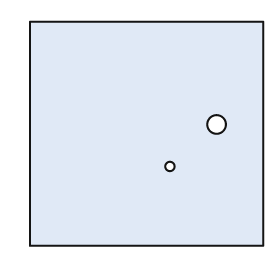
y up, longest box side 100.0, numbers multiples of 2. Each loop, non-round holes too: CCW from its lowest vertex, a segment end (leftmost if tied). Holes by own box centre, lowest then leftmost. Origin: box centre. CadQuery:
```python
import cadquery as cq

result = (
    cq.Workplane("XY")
    .moveTo(-50.0, -48.0)
    .lineTo(50.0, -48.0)
    .lineTo(50.0, 48.0)
    .lineTo(-50.0, 48.0)
    .close()
    .moveTo(10.0, -14.0)
    .circle(2.0)
    .moveTo(30.0, 4.0)
    .circle(4.0)
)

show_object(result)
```